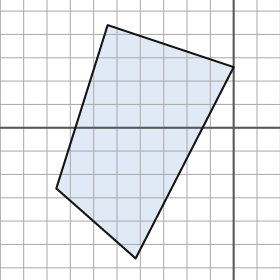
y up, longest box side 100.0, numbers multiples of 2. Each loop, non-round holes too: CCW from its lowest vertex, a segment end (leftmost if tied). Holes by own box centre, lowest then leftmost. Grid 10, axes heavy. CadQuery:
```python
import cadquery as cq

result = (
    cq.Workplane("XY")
    .moveTo(-42.0, -56.0)
    .lineTo(0.0, 26.0)
    .lineTo(-54.0, 44.0)
    .lineTo(-76.0, -26.0)
    .close()
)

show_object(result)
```